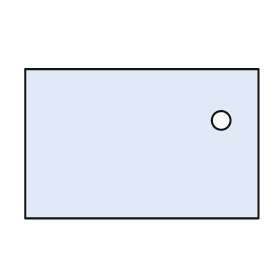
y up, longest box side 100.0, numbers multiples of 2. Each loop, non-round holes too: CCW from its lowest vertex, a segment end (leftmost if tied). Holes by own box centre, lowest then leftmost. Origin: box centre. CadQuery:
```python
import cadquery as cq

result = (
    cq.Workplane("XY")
    .moveTo(-50.0, -32.0)
    .lineTo(50.0, -32.0)
    .lineTo(50.0, 32.0)
    .lineTo(-50.0, 32.0)
    .close()
    .moveTo(34.0, 10.0)
    .circle(4.0)
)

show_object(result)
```